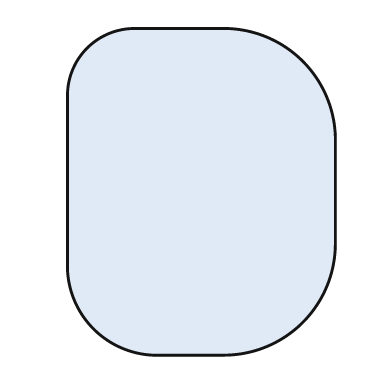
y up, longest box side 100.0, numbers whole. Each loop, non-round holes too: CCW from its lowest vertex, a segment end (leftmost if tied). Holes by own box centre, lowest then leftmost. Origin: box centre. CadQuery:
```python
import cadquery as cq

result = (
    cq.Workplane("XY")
    .moveTo(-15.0, -50.0)
    .lineTo(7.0, -50.0)
    .threePointArc((31.0, -40.0), (41.0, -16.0))
    .lineTo(41.0, 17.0)
    .threePointArc((31.0, 40.0), (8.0, 50.0))
    .lineTo(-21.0, 50.0)
    .threePointArc((-35.0, 44.0), (-41.0, 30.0))
    .lineTo(-41.0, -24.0)
    .threePointArc((-33.0, -42.0), (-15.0, -50.0))
    .close()
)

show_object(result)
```